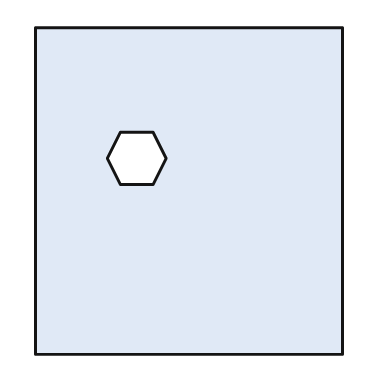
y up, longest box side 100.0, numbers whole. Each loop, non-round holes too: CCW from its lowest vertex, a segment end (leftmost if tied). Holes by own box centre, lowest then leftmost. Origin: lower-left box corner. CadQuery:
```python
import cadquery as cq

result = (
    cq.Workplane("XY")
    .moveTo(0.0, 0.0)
    .lineTo(94.0, 0.0)
    .lineTo(94.0, 100.0)
    .lineTo(0.0, 100.0)
    .close()
    .moveTo(26.0, 52.0)
    .lineTo(36.0, 52.0)
    .lineTo(40.0, 60.0)
    .lineTo(36.0, 68.0)
    .lineTo(26.0, 68.0)
    .lineTo(22.0, 60.0)
    .close()
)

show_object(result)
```